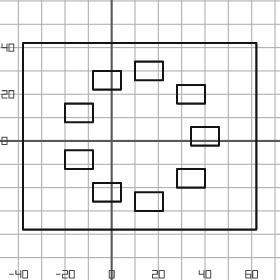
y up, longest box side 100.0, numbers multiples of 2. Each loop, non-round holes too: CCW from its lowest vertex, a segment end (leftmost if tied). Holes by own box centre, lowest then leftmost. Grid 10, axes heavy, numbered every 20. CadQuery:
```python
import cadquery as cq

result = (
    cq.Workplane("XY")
    .moveTo(-38.0, -38.0)
    .lineTo(62.0, -38.0)
    .lineTo(62.0, 42.0)
    .lineTo(-38.0, 42.0)
    .close()
    .moveTo(10.0, -30.0)
    .lineTo(22.0, -30.0)
    .lineTo(22.0, -22.0)
    .lineTo(10.0, -22.0)
    .close()
    .moveTo(-8.0, -26.0)
    .lineTo(4.0, -26.0)
    .lineTo(4.0, -18.0)
    .lineTo(-8.0, -18.0)
    .close()
    .moveTo(28.0, -20.0)
    .lineTo(40.0, -20.0)
    .lineTo(40.0, -12.0)
    .lineTo(28.0, -12.0)
    .close()
    .moveTo(-20.0, -12.0)
    .lineTo(-8.0, -12.0)
    .lineTo(-8.0, -4.0)
    .lineTo(-20.0, -4.0)
    .close()
    .moveTo(34.0, -2.0)
    .lineTo(46.0, -2.0)
    .lineTo(46.0, 6.0)
    .lineTo(34.0, 6.0)
    .close()
    .moveTo(-20.0, 8.0)
    .lineTo(-8.0, 8.0)
    .lineTo(-8.0, 16.0)
    .lineTo(-20.0, 16.0)
    .close()
    .moveTo(28.0, 16.0)
    .lineTo(40.0, 16.0)
    .lineTo(40.0, 24.0)
    .lineTo(28.0, 24.0)
    .close()
    .moveTo(-8.0, 22.0)
    .lineTo(4.0, 22.0)
    .lineTo(4.0, 30.0)
    .lineTo(-8.0, 30.0)
    .close()
    .moveTo(10.0, 26.0)
    .lineTo(22.0, 26.0)
    .lineTo(22.0, 34.0)
    .lineTo(10.0, 34.0)
    .close()
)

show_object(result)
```